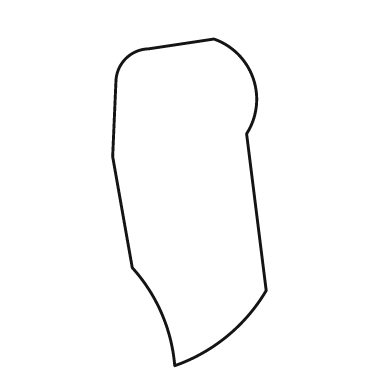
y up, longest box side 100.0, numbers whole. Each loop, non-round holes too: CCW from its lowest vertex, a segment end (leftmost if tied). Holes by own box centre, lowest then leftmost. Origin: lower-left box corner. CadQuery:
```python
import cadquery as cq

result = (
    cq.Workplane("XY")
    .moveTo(19.0, 0.0)
    .threePointArc((35.0, 9.0), (47.0, 23.0))
    .lineTo(41.0, 71.0)
    .threePointArc((43.0, 88.0), (31.0, 100.0))
    .lineTo(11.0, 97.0)
    .threePointArc((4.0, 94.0), (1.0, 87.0))
    .lineTo(0.0, 64.0)
    .lineTo(6.0, 30.0)
    .threePointArc((15.0, 16.0), (19.0, 0.0))
    .close()
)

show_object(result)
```